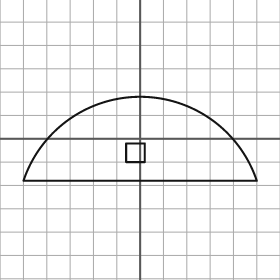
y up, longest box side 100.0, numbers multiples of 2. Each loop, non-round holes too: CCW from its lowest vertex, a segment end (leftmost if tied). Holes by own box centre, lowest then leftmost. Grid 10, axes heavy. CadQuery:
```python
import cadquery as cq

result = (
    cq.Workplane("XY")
    .moveTo(-50.0, -18.0)
    .lineTo(50.0, -18.0)
    .threePointArc((0.0, 18.0), (-50.0, -18.0))
    .close()
    .moveTo(-6.0, -10.0)
    .lineTo(2.0, -10.0)
    .lineTo(2.0, -2.0)
    .lineTo(-6.0, -2.0)
    .close()
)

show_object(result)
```